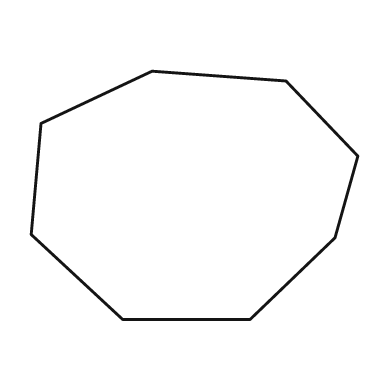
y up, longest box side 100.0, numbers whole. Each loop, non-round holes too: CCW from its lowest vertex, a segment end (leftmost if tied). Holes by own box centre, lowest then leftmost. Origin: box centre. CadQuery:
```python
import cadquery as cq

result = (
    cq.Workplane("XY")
    .moveTo(-22.0, -38.0)
    .lineTo(17.0, -38.0)
    .lineTo(43.0, -13.0)
    .lineTo(50.0, 12.0)
    .lineTo(28.0, 35.0)
    .lineTo(-13.0, 38.0)
    .lineTo(-47.0, 22.0)
    .lineTo(-50.0, -12.0)
    .close()
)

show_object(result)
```